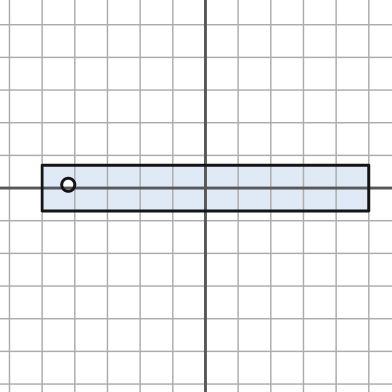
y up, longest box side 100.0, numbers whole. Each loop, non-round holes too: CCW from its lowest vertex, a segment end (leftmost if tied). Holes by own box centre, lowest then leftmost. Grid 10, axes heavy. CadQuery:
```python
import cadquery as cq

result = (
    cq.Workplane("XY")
    .moveTo(-50.0, -7.0)
    .lineTo(50.0, -7.0)
    .lineTo(50.0, 7.0)
    .lineTo(-50.0, 7.0)
    .close()
    .moveTo(-42.0, 1.0)
    .circle(2.0)
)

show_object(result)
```